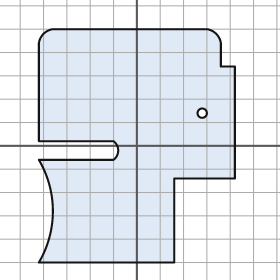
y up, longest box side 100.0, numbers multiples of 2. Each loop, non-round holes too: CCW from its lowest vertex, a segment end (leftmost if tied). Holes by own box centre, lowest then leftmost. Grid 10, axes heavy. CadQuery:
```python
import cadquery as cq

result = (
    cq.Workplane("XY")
    .moveTo(-42.0, -50.0)
    .lineTo(16.0, -50.0)
    .lineTo(16.0, -14.0)
    .lineTo(42.0, -14.0)
    .lineTo(42.0, 34.0)
    .lineTo(36.0, 34.0)
    .lineTo(36.0, 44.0)
    .threePointArc((34.0, 48.0), (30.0, 50.0))
    .lineTo(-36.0, 50.0)
    .threePointArc((-40.0, 48.0), (-42.0, 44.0))
    .lineTo(-42.0, 2.0)
    .lineTo(-10.0, 2.0)
    .threePointArc((-8.0, -2.0), (-10.0, -6.0))
    .lineTo(-42.0, -6.0)
    .threePointArc((-36.0, -28.0), (-42.0, -50.0))
    .close()
    .moveTo(28.0, 14.0)
    .circle(2.0)
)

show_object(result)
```